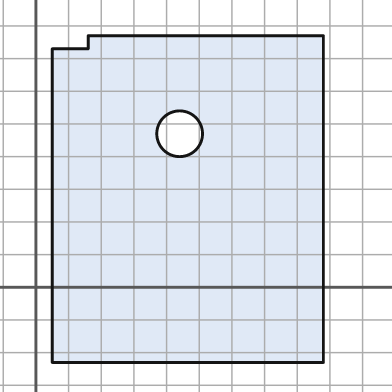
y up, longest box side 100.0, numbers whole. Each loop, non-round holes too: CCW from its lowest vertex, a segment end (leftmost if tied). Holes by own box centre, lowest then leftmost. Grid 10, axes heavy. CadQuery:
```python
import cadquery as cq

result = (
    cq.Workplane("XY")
    .moveTo(5.0, -23.0)
    .lineTo(88.0, -23.0)
    .lineTo(88.0, 77.0)
    .lineTo(16.0, 77.0)
    .lineTo(16.0, 73.0)
    .lineTo(5.0, 73.0)
    .close()
    .moveTo(44.0, 47.0)
    .circle(7.0)
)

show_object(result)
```